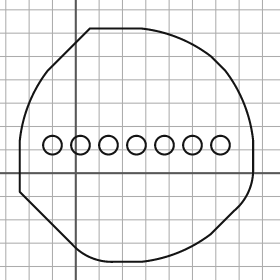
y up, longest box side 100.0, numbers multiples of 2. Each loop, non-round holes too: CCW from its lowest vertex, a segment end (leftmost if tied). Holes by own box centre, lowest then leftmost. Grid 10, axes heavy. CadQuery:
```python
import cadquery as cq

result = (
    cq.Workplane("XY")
    .moveTo(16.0, -38.0)
    .lineTo(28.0, -38.0)
    .threePointArc((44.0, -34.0), (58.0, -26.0))
    .lineTo(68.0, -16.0)
    .threePointArc((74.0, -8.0), (76.0, 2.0))
    .lineTo(76.0, 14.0)
    .threePointArc((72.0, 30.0), (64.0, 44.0))
    .lineTo(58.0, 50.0)
    .threePointArc((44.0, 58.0), (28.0, 62.0))
    .lineTo(6.0, 62.0)
    .lineTo(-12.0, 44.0)
    .threePointArc((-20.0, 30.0), (-24.0, 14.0))
    .lineTo(-24.0, -8.0)
    .lineTo(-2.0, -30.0)
    .threePointArc((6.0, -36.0), (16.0, -38.0))
    .close()
    .moveTo(-10.0, 12.0)
    .circle(4.0)
    .moveTo(2.0, 12.0)
    .circle(4.0)
    .moveTo(14.0, 12.0)
    .circle(4.0)
    .moveTo(26.0, 12.0)
    .circle(4.0)
    .moveTo(38.0, 12.0)
    .circle(4.0)
    .moveTo(50.0, 12.0)
    .circle(4.0)
    .moveTo(62.0, 12.0)
    .circle(4.0)
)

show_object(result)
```